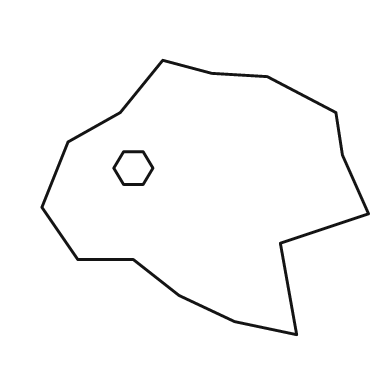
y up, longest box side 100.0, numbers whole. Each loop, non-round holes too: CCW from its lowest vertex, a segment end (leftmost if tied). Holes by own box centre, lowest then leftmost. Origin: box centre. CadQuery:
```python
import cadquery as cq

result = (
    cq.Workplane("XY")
    .moveTo(28.0, -42.0)
    .lineTo(23.0, -14.0)
    .lineTo(50.0, -5.0)
    .lineTo(42.0, 13.0)
    .lineTo(40.0, 26.0)
    .lineTo(19.0, 37.0)
    .lineTo(2.0, 38.0)
    .lineTo(-13.0, 42.0)
    .lineTo(-26.0, 26.0)
    .lineTo(-42.0, 17.0)
    .lineTo(-50.0, -3.0)
    .lineTo(-39.0, -19.0)
    .lineTo(-22.0, -19.0)
    .lineTo(-8.0, -30.0)
    .lineTo(9.0, -38.0)
    .close()
    .moveTo(-25.0, 4.0)
    .lineTo(-19.0, 4.0)
    .lineTo(-16.0, 9.0)
    .lineTo(-19.0, 14.0)
    .lineTo(-25.0, 14.0)
    .lineTo(-28.0, 9.0)
    .close()
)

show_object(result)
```